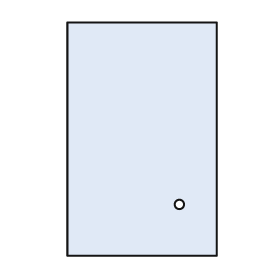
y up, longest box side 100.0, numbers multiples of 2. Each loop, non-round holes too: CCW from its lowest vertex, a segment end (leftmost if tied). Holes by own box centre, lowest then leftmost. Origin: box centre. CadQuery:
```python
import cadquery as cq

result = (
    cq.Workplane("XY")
    .moveTo(-32.0, -50.0)
    .lineTo(32.0, -50.0)
    .lineTo(32.0, 50.0)
    .lineTo(-32.0, 50.0)
    .close()
    .moveTo(16.0, -28.0)
    .circle(2.0)
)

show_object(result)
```